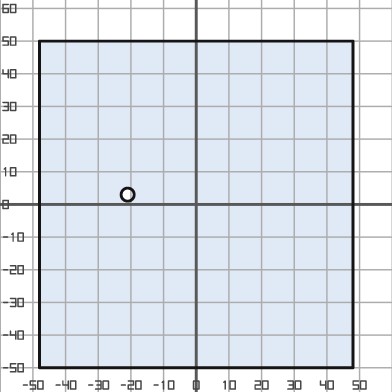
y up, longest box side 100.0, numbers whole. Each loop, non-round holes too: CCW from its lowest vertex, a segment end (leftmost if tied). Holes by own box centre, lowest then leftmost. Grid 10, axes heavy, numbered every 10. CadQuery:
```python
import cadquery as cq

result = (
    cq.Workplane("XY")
    .moveTo(-48.0, -50.0)
    .lineTo(48.0, -50.0)
    .lineTo(48.0, 50.0)
    .lineTo(-48.0, 50.0)
    .close()
    .moveTo(-21.0, 3.0)
    .circle(2.0)
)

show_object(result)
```